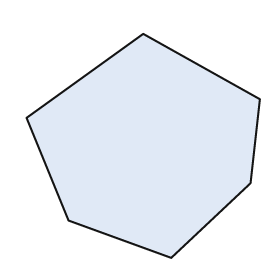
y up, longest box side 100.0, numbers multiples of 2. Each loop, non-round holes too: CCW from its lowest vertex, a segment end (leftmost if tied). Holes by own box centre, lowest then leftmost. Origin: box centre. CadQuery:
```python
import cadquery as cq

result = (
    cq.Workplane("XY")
    .moveTo(12.0, -48.0)
    .lineTo(46.0, -16.0)
    .lineTo(50.0, 20.0)
    .lineTo(0.0, 48.0)
    .lineTo(-50.0, 12.0)
    .lineTo(-32.0, -32.0)
    .close()
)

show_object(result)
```